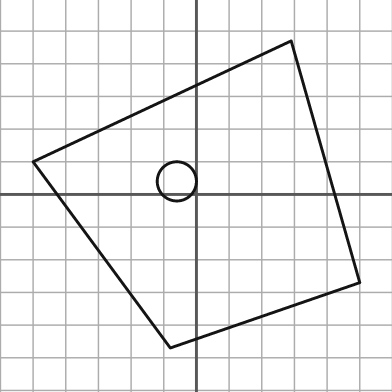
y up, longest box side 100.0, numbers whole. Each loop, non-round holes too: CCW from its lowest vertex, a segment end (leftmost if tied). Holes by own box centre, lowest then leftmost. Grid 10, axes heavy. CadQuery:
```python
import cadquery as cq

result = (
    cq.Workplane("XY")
    .moveTo(-8.0, -47.0)
    .lineTo(50.0, -27.0)
    .lineTo(29.0, 47.0)
    .lineTo(-50.0, 10.0)
    .close()
    .moveTo(-6.0, 4.0)
    .circle(6.0)
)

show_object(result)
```